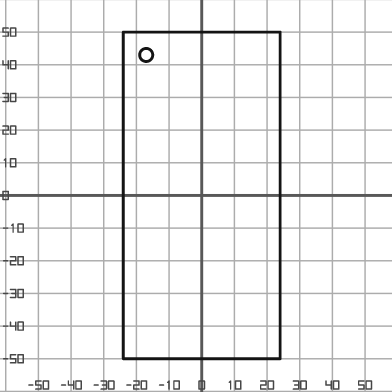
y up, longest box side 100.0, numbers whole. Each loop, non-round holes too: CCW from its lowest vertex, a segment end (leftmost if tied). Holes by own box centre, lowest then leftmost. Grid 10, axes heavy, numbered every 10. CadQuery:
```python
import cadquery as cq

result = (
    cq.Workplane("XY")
    .moveTo(-24.0, -50.0)
    .lineTo(24.0, -50.0)
    .lineTo(24.0, 50.0)
    .lineTo(-24.0, 50.0)
    .close()
    .moveTo(-17.0, 43.0)
    .circle(2.0)
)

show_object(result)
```